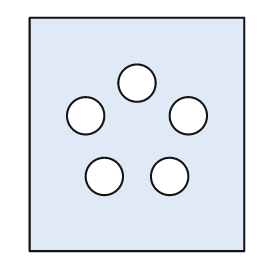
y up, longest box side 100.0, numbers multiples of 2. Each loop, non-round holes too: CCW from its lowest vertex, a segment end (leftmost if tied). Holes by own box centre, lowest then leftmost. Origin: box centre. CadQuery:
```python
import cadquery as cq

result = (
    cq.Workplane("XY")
    .moveTo(-46.0, -50.0)
    .lineTo(46.0, -50.0)
    .lineTo(46.0, 50.0)
    .lineTo(-46.0, 50.0)
    .close()
    .moveTo(-14.0, -18.0)
    .circle(8.0)
    .moveTo(14.0, -18.0)
    .circle(8.0)
    .moveTo(-22.0, 8.0)
    .circle(8.0)
    .moveTo(22.0, 8.0)
    .circle(8.0)
    .moveTo(0.0, 22.0)
    .circle(8.0)
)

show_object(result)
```